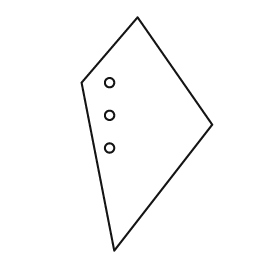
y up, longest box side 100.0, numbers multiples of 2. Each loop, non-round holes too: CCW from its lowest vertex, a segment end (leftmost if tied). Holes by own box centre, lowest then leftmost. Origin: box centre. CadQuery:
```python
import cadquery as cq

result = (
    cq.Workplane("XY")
    .moveTo(-14.0, -50.0)
    .lineTo(28.0, 4.0)
    .lineTo(-4.0, 50.0)
    .lineTo(-28.0, 22.0)
    .close()
    .moveTo(-16.0, -6.0)
    .circle(2.0)
    .moveTo(-16.0, 8.0)
    .circle(2.0)
    .moveTo(-16.0, 22.0)
    .circle(2.0)
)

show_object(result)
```